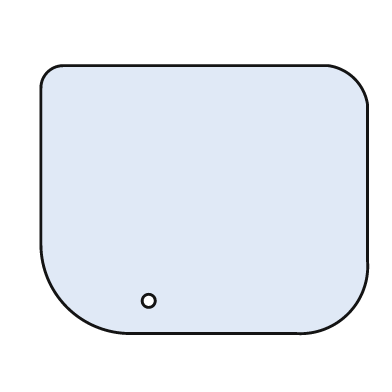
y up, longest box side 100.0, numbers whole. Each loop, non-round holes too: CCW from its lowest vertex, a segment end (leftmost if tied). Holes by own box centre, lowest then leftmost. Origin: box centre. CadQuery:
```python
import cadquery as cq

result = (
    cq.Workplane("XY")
    .moveTo(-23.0, -41.0)
    .lineTo(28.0, -41.0)
    .threePointArc((44.0, -35.0), (50.0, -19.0))
    .lineTo(50.0, 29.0)
    .threePointArc((46.0, 37.0), (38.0, 41.0))
    .lineTo(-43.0, 41.0)
    .threePointArc((-48.0, 39.0), (-50.0, 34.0))
    .lineTo(-50.0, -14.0)
    .threePointArc((-42.0, -33.0), (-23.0, -41.0))
    .close()
    .moveTo(-17.0, -31.0)
    .circle(2.0)
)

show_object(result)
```